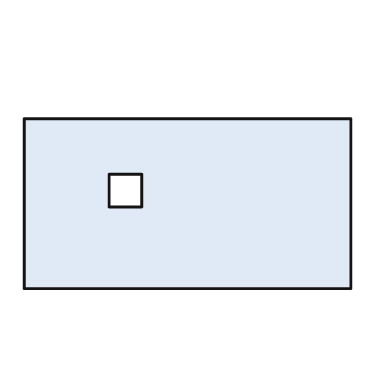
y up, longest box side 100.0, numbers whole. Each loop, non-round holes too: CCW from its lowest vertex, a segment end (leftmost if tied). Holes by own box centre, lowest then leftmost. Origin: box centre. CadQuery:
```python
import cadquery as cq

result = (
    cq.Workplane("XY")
    .moveTo(-50.0, -26.0)
    .lineTo(50.0, -26.0)
    .lineTo(50.0, 26.0)
    .lineTo(-50.0, 26.0)
    .close()
    .moveTo(-24.0, -1.0)
    .lineTo(-14.0, -1.0)
    .lineTo(-14.0, 9.0)
    .lineTo(-24.0, 9.0)
    .close()
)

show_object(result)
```